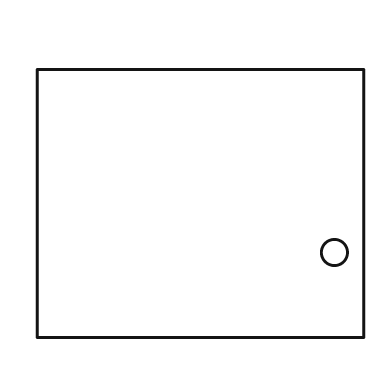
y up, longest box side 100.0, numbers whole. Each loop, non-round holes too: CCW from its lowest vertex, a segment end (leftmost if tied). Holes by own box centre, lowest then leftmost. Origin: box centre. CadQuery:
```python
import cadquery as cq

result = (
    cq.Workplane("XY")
    .moveTo(-50.0, -41.0)
    .lineTo(50.0, -41.0)
    .lineTo(50.0, 41.0)
    .lineTo(-50.0, 41.0)
    .close()
    .moveTo(41.0, -15.0)
    .circle(4.0)
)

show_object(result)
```